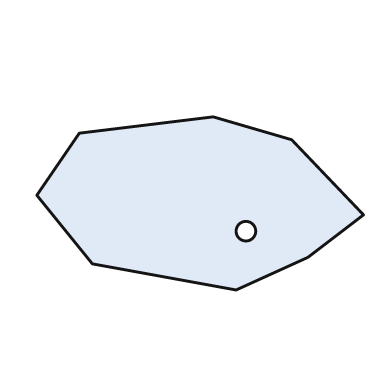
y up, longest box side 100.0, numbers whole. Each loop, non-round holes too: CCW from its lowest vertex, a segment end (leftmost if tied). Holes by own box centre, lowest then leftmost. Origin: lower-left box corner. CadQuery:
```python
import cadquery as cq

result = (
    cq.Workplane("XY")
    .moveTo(61.0, 0.0)
    .lineTo(83.0, 10.0)
    .lineTo(100.0, 23.0)
    .lineTo(78.0, 46.0)
    .lineTo(54.0, 53.0)
    .lineTo(13.0, 48.0)
    .lineTo(0.0, 29.0)
    .lineTo(17.0, 8.0)
    .close()
    .moveTo(64.0, 18.0)
    .circle(3.0)
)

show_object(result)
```